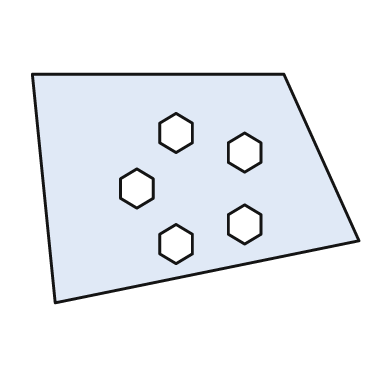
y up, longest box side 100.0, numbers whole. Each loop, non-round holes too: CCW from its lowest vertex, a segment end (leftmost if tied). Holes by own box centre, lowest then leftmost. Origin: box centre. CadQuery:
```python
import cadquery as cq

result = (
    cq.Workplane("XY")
    .moveTo(-43.0, -35.0)
    .lineTo(50.0, -16.0)
    .lineTo(27.0, 35.0)
    .lineTo(-50.0, 35.0)
    .close()
    .moveTo(-6.0, -23.0)
    .lineTo(-1.0, -20.0)
    .lineTo(-1.0, -14.0)
    .lineTo(-6.0, -11.0)
    .lineTo(-11.0, -14.0)
    .lineTo(-11.0, -20.0)
    .close()
    .moveTo(15.0, -17.0)
    .lineTo(20.0, -14.0)
    .lineTo(20.0, -8.0)
    .lineTo(15.0, -5.0)
    .lineTo(10.0, -8.0)
    .lineTo(10.0, -14.0)
    .close()
    .moveTo(-18.0, -6.0)
    .lineTo(-13.0, -3.0)
    .lineTo(-13.0, 3.0)
    .lineTo(-18.0, 6.0)
    .lineTo(-23.0, 3.0)
    .lineTo(-23.0, -3.0)
    .close()
    .moveTo(15.0, 5.0)
    .lineTo(20.0, 8.0)
    .lineTo(20.0, 14.0)
    .lineTo(15.0, 17.0)
    .lineTo(10.0, 14.0)
    .lineTo(10.0, 8.0)
    .close()
    .moveTo(-6.0, 11.0)
    .lineTo(-1.0, 14.0)
    .lineTo(-1.0, 20.0)
    .lineTo(-6.0, 23.0)
    .lineTo(-11.0, 20.0)
    .lineTo(-11.0, 14.0)
    .close()
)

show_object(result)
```